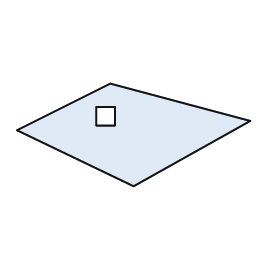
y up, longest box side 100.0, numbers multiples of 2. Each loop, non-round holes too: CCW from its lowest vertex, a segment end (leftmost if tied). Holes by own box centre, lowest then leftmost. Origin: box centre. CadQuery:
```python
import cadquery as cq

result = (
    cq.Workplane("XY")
    .moveTo(0.0, -22.0)
    .lineTo(50.0, 6.0)
    .lineTo(-10.0, 22.0)
    .lineTo(-50.0, 2.0)
    .close()
    .moveTo(-16.0, 4.0)
    .lineTo(-8.0, 4.0)
    .lineTo(-8.0, 12.0)
    .lineTo(-16.0, 12.0)
    .close()
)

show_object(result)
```